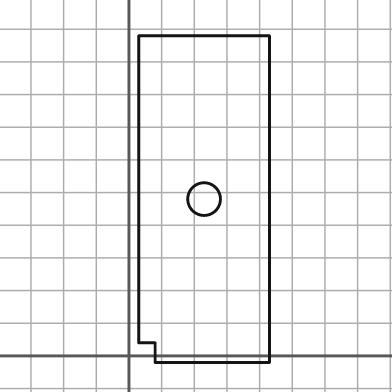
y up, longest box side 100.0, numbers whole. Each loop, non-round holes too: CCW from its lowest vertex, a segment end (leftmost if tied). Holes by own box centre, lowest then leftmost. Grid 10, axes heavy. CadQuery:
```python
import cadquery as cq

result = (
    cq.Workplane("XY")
    .moveTo(8.0, -2.0)
    .lineTo(43.0, -2.0)
    .lineTo(43.0, 98.0)
    .lineTo(3.0, 98.0)
    .lineTo(3.0, 4.0)
    .lineTo(8.0, 4.0)
    .close()
    .moveTo(23.0, 48.0)
    .circle(5.0)
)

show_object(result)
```